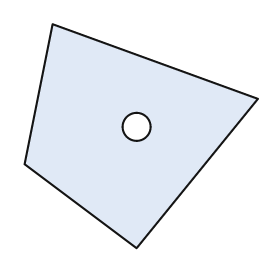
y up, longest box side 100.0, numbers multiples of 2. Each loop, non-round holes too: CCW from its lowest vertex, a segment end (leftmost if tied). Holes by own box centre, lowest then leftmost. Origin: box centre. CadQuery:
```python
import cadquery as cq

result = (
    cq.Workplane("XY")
    .moveTo(-2.0, -48.0)
    .lineTo(50.0, 16.0)
    .lineTo(-38.0, 48.0)
    .lineTo(-50.0, -12.0)
    .close()
    .moveTo(-2.0, 4.0)
    .circle(6.0)
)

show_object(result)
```